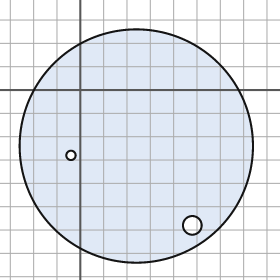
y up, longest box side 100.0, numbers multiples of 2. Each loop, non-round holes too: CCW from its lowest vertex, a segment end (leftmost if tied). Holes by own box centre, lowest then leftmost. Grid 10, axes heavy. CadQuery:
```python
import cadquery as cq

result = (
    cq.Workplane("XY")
    .moveTo(24.0, -24.0)
    .circle(50.0)
    .moveTo(48.0, -58.0)
    .circle(4.0)
    .moveTo(-4.0, -28.0)
    .circle(2.0)
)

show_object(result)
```